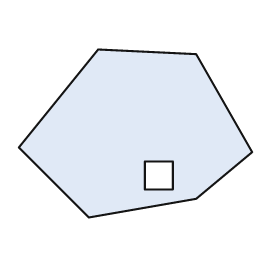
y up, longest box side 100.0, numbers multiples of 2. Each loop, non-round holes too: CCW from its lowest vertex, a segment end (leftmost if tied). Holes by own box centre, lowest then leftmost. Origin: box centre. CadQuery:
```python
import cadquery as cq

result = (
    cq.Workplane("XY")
    .moveTo(-20.0, -36.0)
    .lineTo(26.0, -28.0)
    .lineTo(50.0, -8.0)
    .lineTo(26.0, 34.0)
    .lineTo(-16.0, 36.0)
    .lineTo(-50.0, -6.0)
    .close()
    .moveTo(4.0, -24.0)
    .lineTo(16.0, -24.0)
    .lineTo(16.0, -12.0)
    .lineTo(4.0, -12.0)
    .close()
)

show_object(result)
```